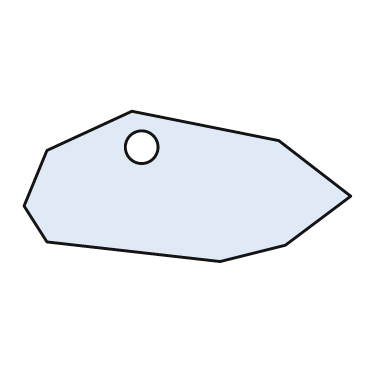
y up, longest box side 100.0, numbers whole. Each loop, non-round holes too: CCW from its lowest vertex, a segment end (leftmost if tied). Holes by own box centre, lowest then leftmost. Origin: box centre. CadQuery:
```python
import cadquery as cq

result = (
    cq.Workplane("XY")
    .moveTo(10.0, -23.0)
    .lineTo(30.0, -18.0)
    .lineTo(50.0, -3.0)
    .lineTo(28.0, 14.0)
    .lineTo(-17.0, 23.0)
    .lineTo(-43.0, 11.0)
    .lineTo(-50.0, -6.0)
    .lineTo(-43.0, -17.0)
    .close()
    .moveTo(-14.0, 12.0)
    .circle(5.0)
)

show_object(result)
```